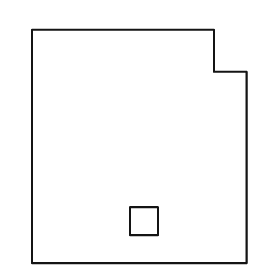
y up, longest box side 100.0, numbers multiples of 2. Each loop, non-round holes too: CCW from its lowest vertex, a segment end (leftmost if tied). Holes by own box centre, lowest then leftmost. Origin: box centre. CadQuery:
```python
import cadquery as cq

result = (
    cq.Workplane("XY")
    .moveTo(-46.0, -50.0)
    .lineTo(46.0, -50.0)
    .lineTo(46.0, 32.0)
    .lineTo(32.0, 32.0)
    .lineTo(32.0, 50.0)
    .lineTo(-46.0, 50.0)
    .close()
    .moveTo(-4.0, -38.0)
    .lineTo(8.0, -38.0)
    .lineTo(8.0, -26.0)
    .lineTo(-4.0, -26.0)
    .close()
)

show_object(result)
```